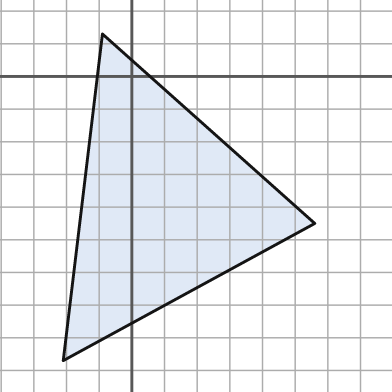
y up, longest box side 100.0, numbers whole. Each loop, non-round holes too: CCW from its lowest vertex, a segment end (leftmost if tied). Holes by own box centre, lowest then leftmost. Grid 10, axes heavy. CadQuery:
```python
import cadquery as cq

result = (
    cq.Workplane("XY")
    .moveTo(-21.0, -87.0)
    .lineTo(56.0, -45.0)
    .lineTo(-9.0, 13.0)
    .close()
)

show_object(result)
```